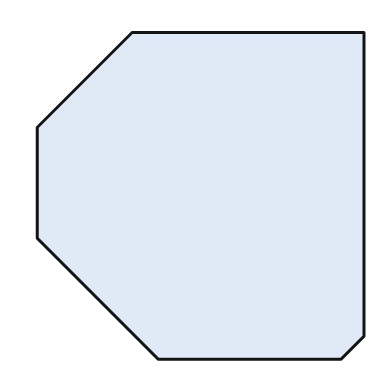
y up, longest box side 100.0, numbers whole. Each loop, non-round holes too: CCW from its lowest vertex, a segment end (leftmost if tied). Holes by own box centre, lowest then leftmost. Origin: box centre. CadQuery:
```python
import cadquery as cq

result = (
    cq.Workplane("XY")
    .moveTo(-13.0, -50.0)
    .lineTo(43.0, -50.0)
    .lineTo(50.0, -43.0)
    .lineTo(50.0, 50.0)
    .lineTo(-21.0, 50.0)
    .lineTo(-50.0, 21.0)
    .lineTo(-50.0, -13.0)
    .close()
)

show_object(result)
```